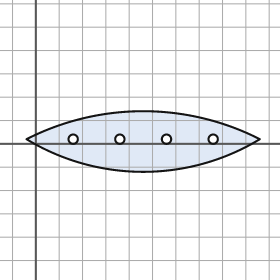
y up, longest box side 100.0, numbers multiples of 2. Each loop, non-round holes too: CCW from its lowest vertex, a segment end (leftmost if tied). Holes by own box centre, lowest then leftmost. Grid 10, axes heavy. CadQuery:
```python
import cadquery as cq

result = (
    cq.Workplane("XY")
    .moveTo(-4.0, 2.0)
    .threePointArc((46.0, -12.0), (96.0, 2.0))
    .threePointArc((46.0, 14.0), (-4.0, 2.0))
    .close()
    .moveTo(16.0, 2.0)
    .circle(2.0)
    .moveTo(36.0, 2.0)
    .circle(2.0)
    .moveTo(56.0, 2.0)
    .circle(2.0)
    .moveTo(76.0, 2.0)
    .circle(2.0)
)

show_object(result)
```